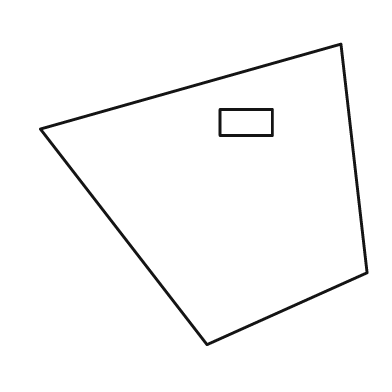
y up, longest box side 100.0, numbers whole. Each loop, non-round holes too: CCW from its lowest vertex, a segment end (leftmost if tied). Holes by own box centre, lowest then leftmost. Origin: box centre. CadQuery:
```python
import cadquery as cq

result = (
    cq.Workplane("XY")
    .moveTo(1.0, -46.0)
    .lineTo(50.0, -24.0)
    .lineTo(42.0, 46.0)
    .lineTo(-50.0, 20.0)
    .close()
    .moveTo(5.0, 18.0)
    .lineTo(21.0, 18.0)
    .lineTo(21.0, 26.0)
    .lineTo(5.0, 26.0)
    .close()
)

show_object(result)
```